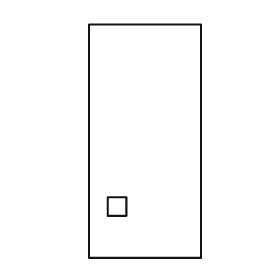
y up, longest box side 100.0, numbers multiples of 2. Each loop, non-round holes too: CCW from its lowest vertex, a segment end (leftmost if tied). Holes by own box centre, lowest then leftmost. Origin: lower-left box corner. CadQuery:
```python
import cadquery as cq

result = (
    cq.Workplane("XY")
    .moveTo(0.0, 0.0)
    .lineTo(48.0, 0.0)
    .lineTo(48.0, 100.0)
    .lineTo(0.0, 100.0)
    .close()
    .moveTo(8.0, 18.0)
    .lineTo(16.0, 18.0)
    .lineTo(16.0, 26.0)
    .lineTo(8.0, 26.0)
    .close()
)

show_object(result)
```